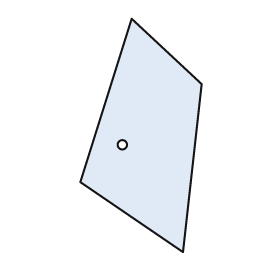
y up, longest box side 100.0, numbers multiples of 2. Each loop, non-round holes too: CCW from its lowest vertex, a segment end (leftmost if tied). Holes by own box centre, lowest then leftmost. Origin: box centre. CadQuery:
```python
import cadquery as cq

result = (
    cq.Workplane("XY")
    .moveTo(18.0, -50.0)
    .lineTo(26.0, 22.0)
    .lineTo(-4.0, 50.0)
    .lineTo(-26.0, -20.0)
    .close()
    .moveTo(-8.0, -4.0)
    .circle(2.0)
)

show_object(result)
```